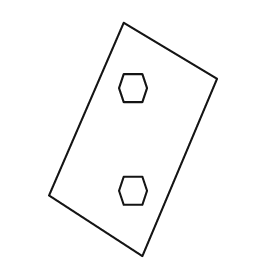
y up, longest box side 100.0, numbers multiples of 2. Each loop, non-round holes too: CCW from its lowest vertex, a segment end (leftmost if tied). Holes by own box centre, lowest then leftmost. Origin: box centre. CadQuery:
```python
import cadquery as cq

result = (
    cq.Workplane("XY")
    .moveTo(4.0, -50.0)
    .lineTo(36.0, 26.0)
    .lineTo(-4.0, 50.0)
    .lineTo(-36.0, -24.0)
    .close()
    .moveTo(-4.0, -28.0)
    .lineTo(4.0, -28.0)
    .lineTo(6.0, -22.0)
    .lineTo(4.0, -16.0)
    .lineTo(-4.0, -16.0)
    .lineTo(-6.0, -22.0)
    .close()
    .moveTo(-4.0, 16.0)
    .lineTo(4.0, 16.0)
    .lineTo(6.0, 22.0)
    .lineTo(4.0, 28.0)
    .lineTo(-4.0, 28.0)
    .lineTo(-6.0, 22.0)
    .close()
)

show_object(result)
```